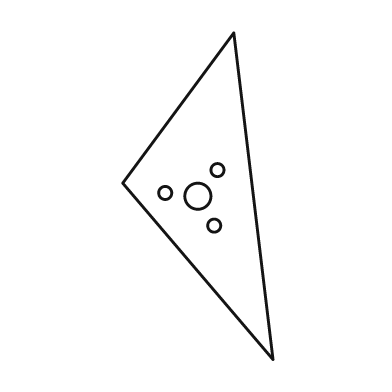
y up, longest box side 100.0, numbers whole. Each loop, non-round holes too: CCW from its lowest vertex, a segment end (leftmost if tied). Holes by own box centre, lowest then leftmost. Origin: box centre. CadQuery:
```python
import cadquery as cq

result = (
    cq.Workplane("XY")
    .moveTo(23.0, -50.0)
    .lineTo(11.0, 50.0)
    .lineTo(-23.0, 4.0)
    .close()
    .moveTo(5.0, -9.0)
    .circle(2.0)
    .moveTo(0.0, 0.0)
    .circle(4.0)
    .moveTo(-10.0, 1.0)
    .circle(2.0)
    .moveTo(6.0, 8.0)
    .circle(2.0)
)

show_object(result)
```